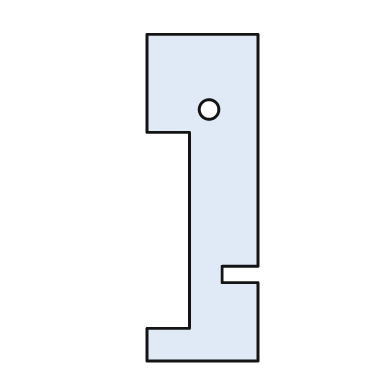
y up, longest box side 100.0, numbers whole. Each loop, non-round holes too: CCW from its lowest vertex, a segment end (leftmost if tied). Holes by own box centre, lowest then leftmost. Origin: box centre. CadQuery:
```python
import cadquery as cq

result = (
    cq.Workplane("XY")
    .moveTo(-17.0, -50.0)
    .lineTo(17.0, -50.0)
    .lineTo(17.0, -26.0)
    .lineTo(6.0, -26.0)
    .lineTo(6.0, -21.0)
    .lineTo(17.0, -21.0)
    .lineTo(17.0, 50.0)
    .lineTo(-17.0, 50.0)
    .lineTo(-17.0, 20.0)
    .lineTo(-4.0, 20.0)
    .lineTo(-4.0, -40.0)
    .lineTo(-17.0, -40.0)
    .close()
    .moveTo(2.0, 27.0)
    .circle(3.0)
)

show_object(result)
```